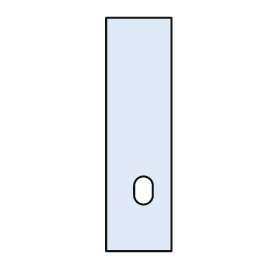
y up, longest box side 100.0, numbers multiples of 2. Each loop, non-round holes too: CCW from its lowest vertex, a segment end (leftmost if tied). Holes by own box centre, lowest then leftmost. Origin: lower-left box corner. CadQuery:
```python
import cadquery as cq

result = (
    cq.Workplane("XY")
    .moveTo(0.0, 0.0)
    .lineTo(28.0, 0.0)
    .lineTo(28.0, 100.0)
    .lineTo(0.0, 100.0)
    .close()
    .moveTo(12.0, 24.0)
    .threePointArc((16.0, 20.0), (20.0, 24.0))
    .lineTo(20.0, 28.0)
    .threePointArc((16.0, 32.0), (12.0, 28.0))
    .close()
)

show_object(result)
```